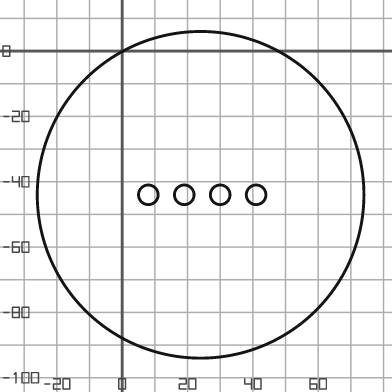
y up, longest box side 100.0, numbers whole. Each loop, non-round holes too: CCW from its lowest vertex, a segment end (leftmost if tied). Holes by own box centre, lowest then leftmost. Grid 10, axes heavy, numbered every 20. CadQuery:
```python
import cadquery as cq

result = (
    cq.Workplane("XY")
    .moveTo(24.0, -44.0)
    .circle(50.0)
    .moveTo(8.0, -44.0)
    .circle(3.0)
    .moveTo(19.0, -44.0)
    .circle(3.0)
    .moveTo(30.0, -44.0)
    .circle(3.0)
    .moveTo(41.0, -44.0)
    .circle(3.0)
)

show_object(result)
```